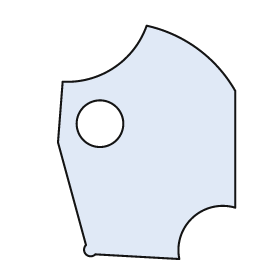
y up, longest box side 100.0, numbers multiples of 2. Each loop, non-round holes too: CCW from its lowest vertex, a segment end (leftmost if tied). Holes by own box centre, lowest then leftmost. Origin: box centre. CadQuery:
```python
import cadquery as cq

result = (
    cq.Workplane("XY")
    .moveTo(14.0, -50.0)
    .threePointArc((20.0, -32.0), (38.0, -28.0))
    .lineTo(38.0, 22.0)
    .threePointArc((22.0, 40.0), (0.0, 50.0))
    .threePointArc((-14.0, 32.0), (-36.0, 26.0))
    .lineTo(-38.0, 0.0)
    .lineTo(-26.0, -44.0)
    .threePointArc((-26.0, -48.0), (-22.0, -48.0))
    .close()
    .moveTo(-20.0, 8.0)
    .circle(10.0)
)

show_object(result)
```